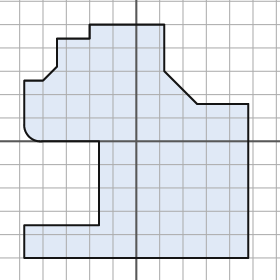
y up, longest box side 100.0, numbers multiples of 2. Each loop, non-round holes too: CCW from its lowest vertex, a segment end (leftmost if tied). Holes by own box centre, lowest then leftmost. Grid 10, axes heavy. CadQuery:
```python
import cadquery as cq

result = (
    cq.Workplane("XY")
    .moveTo(-48.0, -50.0)
    .lineTo(48.0, -50.0)
    .lineTo(48.0, 16.0)
    .lineTo(26.0, 16.0)
    .lineTo(12.0, 30.0)
    .lineTo(12.0, 50.0)
    .lineTo(-20.0, 50.0)
    .lineTo(-20.0, 44.0)
    .lineTo(-34.0, 44.0)
    .lineTo(-34.0, 32.0)
    .lineTo(-40.0, 26.0)
    .lineTo(-48.0, 26.0)
    .lineTo(-48.0, 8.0)
    .threePointArc((-46.0, 2.0), (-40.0, 0.0))
    .lineTo(-16.0, 0.0)
    .lineTo(-16.0, -36.0)
    .lineTo(-48.0, -36.0)
    .close()
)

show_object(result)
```